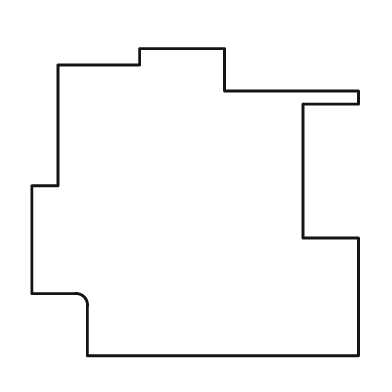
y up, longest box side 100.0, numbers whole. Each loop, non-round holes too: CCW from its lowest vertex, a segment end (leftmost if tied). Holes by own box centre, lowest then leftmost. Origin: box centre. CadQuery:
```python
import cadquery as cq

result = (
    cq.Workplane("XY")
    .moveTo(-33.0, -47.0)
    .lineTo(50.0, -47.0)
    .lineTo(50.0, -11.0)
    .lineTo(33.0, -11.0)
    .lineTo(33.0, 30.0)
    .lineTo(50.0, 30.0)
    .lineTo(50.0, 34.0)
    .lineTo(9.0, 34.0)
    .lineTo(9.0, 47.0)
    .lineTo(-17.0, 47.0)
    .lineTo(-17.0, 42.0)
    .lineTo(-42.0, 42.0)
    .lineTo(-42.0, 5.0)
    .lineTo(-50.0, 5.0)
    .lineTo(-50.0, -28.0)
    .lineTo(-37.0, -28.0)
    .threePointArc((-34.0, -29.0), (-33.0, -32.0))
    .close()
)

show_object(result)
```